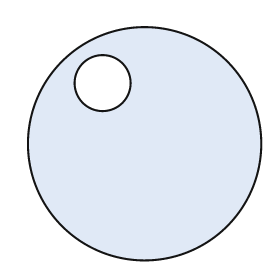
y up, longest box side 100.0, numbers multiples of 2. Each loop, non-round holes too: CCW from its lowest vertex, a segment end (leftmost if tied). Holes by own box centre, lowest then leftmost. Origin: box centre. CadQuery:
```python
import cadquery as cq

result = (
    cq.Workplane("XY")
    .moveTo(0.0, 0.0)
    .circle(50.0)
    .moveTo(-18.0, 26.0)
    .circle(12.0)
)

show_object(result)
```